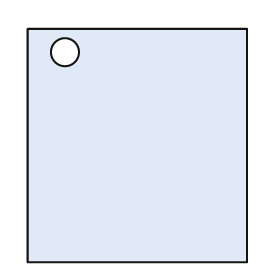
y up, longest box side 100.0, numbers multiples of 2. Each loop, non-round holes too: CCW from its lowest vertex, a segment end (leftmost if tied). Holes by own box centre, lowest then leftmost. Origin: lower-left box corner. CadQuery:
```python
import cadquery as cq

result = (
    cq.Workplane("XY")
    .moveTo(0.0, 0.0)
    .lineTo(94.0, 0.0)
    .lineTo(94.0, 100.0)
    .lineTo(0.0, 100.0)
    .close()
    .moveTo(16.0, 90.0)
    .circle(6.0)
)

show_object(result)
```